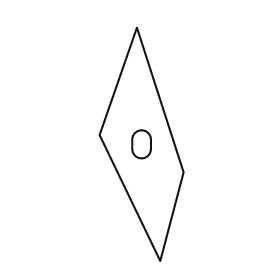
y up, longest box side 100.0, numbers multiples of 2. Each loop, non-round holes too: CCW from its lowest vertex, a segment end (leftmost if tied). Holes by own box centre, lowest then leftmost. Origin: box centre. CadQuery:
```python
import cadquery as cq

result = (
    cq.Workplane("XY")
    .moveTo(8.0, -50.0)
    .lineTo(18.0, -12.0)
    .lineTo(-2.0, 50.0)
    .lineTo(-18.0, 4.0)
    .close()
    .moveTo(-4.0, -2.0)
    .threePointArc((0.0, -6.0), (4.0, -2.0))
    .lineTo(4.0, 2.0)
    .threePointArc((0.0, 6.0), (-4.0, 2.0))
    .close()
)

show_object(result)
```